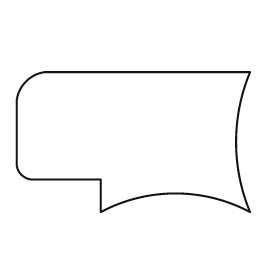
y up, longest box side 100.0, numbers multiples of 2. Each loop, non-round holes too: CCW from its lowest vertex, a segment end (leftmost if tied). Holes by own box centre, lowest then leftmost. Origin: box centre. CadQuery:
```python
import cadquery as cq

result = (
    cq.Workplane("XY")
    .moveTo(-14.0, -30.0)
    .threePointArc((18.0, -22.0), (50.0, -30.0))
    .threePointArc((44.0, 0.0), (50.0, 30.0))
    .lineTo(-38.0, 30.0)
    .threePointArc((-46.0, 26.0), (-50.0, 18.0))
    .lineTo(-50.0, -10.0)
    .threePointArc((-48.0, -14.0), (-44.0, -16.0))
    .lineTo(-14.0, -16.0)
    .close()
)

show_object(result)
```